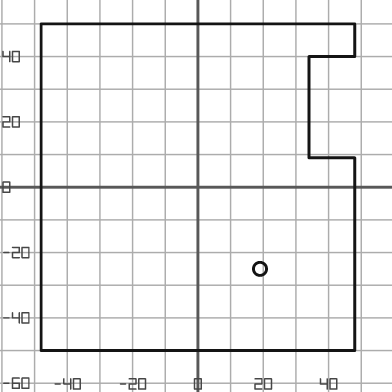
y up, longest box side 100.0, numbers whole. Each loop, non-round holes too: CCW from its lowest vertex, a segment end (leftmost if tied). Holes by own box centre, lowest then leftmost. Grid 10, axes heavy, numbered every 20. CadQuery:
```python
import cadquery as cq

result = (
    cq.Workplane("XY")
    .moveTo(-48.0, -50.0)
    .lineTo(48.0, -50.0)
    .lineTo(48.0, 9.0)
    .lineTo(34.0, 9.0)
    .lineTo(34.0, 40.0)
    .lineTo(48.0, 40.0)
    .lineTo(48.0, 50.0)
    .lineTo(-48.0, 50.0)
    .close()
    .moveTo(19.0, -25.0)
    .circle(2.0)
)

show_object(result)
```